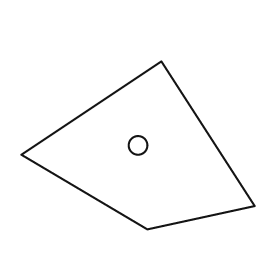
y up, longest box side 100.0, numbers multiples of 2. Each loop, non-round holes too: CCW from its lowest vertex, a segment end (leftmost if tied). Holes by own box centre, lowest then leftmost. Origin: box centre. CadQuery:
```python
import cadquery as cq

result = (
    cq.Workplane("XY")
    .moveTo(4.0, -36.0)
    .lineTo(50.0, -26.0)
    .lineTo(10.0, 36.0)
    .lineTo(-50.0, -4.0)
    .close()
    .moveTo(0.0, 0.0)
    .circle(4.0)
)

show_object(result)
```